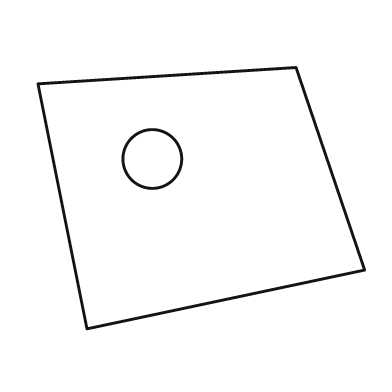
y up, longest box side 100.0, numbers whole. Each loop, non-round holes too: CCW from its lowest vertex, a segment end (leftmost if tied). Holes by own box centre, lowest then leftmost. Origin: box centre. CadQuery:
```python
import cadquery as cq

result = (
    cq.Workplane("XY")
    .moveTo(-35.0, -40.0)
    .lineTo(50.0, -22.0)
    .lineTo(29.0, 40.0)
    .lineTo(-50.0, 35.0)
    .close()
    .moveTo(-15.0, 12.0)
    .circle(9.0)
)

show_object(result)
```